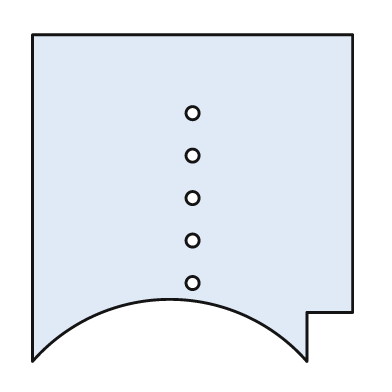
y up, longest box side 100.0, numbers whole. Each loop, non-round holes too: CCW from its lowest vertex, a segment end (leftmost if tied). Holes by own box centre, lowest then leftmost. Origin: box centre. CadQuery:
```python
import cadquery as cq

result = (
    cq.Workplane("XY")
    .moveTo(-49.0, -50.0)
    .threePointArc((-7.0, -31.0), (35.0, -50.0))
    .lineTo(35.0, -35.0)
    .lineTo(49.0, -35.0)
    .lineTo(49.0, 50.0)
    .lineTo(-49.0, 50.0)
    .close()
    .moveTo(0.0, -26.0)
    .circle(2.0)
    .moveTo(0.0, -13.0)
    .circle(2.0)
    .moveTo(0.0, 0.0)
    .circle(2.0)
    .moveTo(0.0, 13.0)
    .circle(2.0)
    .moveTo(0.0, 26.0)
    .circle(2.0)
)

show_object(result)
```